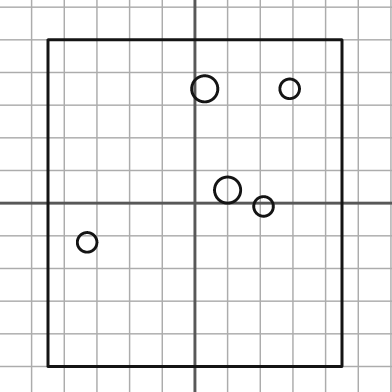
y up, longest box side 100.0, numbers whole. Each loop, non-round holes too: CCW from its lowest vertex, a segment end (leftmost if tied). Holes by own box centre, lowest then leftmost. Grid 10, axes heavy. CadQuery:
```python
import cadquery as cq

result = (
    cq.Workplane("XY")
    .moveTo(-45.0, -50.0)
    .lineTo(45.0, -50.0)
    .lineTo(45.0, 50.0)
    .lineTo(-45.0, 50.0)
    .close()
    .moveTo(-33.0, -12.0)
    .circle(3.0)
    .moveTo(21.0, -1.0)
    .circle(3.0)
    .moveTo(10.0, 4.0)
    .circle(4.0)
    .moveTo(3.0, 35.0)
    .circle(4.0)
    .moveTo(29.0, 35.0)
    .circle(3.0)
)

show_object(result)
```